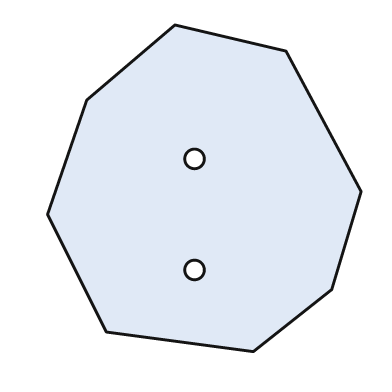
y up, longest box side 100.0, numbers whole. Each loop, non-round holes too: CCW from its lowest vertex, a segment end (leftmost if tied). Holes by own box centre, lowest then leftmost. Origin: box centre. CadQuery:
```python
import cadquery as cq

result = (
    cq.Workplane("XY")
    .moveTo(15.0, -50.0)
    .lineTo(39.0, -31.0)
    .lineTo(48.0, -1.0)
    .lineTo(25.0, 42.0)
    .lineTo(-9.0, 50.0)
    .lineTo(-36.0, 27.0)
    .lineTo(-48.0, -8.0)
    .lineTo(-30.0, -44.0)
    .close()
    .moveTo(-3.0, -25.0)
    .circle(3.0)
    .moveTo(-3.0, 9.0)
    .circle(3.0)
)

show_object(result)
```